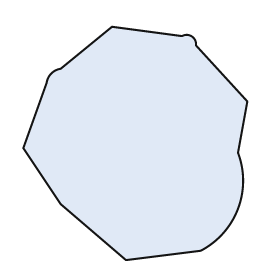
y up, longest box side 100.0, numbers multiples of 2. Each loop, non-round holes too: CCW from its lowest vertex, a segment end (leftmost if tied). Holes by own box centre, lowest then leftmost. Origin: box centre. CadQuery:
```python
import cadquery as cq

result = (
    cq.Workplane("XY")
    .moveTo(-4.0, -50.0)
    .lineTo(28.0, -46.0)
    .threePointArc((44.0, -28.0), (44.0, -4.0))
    .lineTo(48.0, 18.0)
    .lineTo(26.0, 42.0)
    .threePointArc((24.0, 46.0), (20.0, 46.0))
    .lineTo(-10.0, 50.0)
    .lineTo(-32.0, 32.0)
    .threePointArc((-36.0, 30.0), (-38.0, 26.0))
    .lineTo(-48.0, -2.0)
    .lineTo(-32.0, -26.0)
    .close()
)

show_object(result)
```